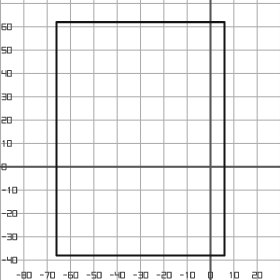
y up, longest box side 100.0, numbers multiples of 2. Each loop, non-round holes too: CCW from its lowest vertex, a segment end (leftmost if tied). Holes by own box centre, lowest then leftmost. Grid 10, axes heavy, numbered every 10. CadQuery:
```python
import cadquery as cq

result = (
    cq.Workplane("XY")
    .moveTo(-66.0, -38.0)
    .lineTo(6.0, -38.0)
    .lineTo(6.0, 62.0)
    .lineTo(-66.0, 62.0)
    .close()
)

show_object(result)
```